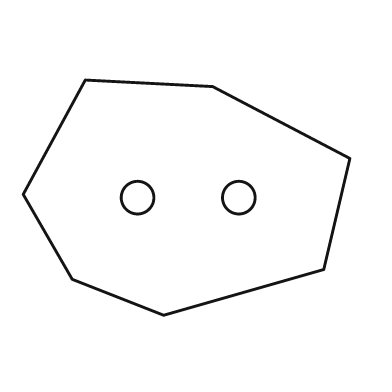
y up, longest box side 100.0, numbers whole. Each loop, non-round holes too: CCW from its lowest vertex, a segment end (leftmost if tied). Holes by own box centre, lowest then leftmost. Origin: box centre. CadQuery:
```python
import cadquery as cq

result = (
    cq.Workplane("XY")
    .moveTo(-7.0, -36.0)
    .lineTo(42.0, -22.0)
    .lineTo(50.0, 12.0)
    .lineTo(8.0, 34.0)
    .lineTo(-31.0, 36.0)
    .lineTo(-50.0, 1.0)
    .lineTo(-35.0, -25.0)
    .close()
    .moveTo(-15.0, 0.0)
    .circle(5.0)
    .moveTo(16.0, 0.0)
    .circle(5.0)
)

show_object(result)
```